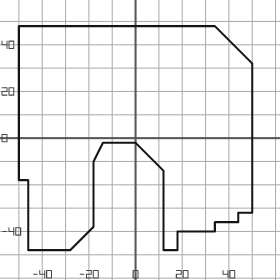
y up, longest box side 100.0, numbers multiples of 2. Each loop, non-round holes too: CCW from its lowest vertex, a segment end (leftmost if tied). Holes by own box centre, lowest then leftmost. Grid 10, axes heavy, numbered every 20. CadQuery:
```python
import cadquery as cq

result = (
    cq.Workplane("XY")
    .moveTo(-46.0, -48.0)
    .lineTo(-28.0, -48.0)
    .lineTo(-18.0, -38.0)
    .lineTo(-18.0, -10.0)
    .lineTo(-14.0, -2.0)
    .lineTo(0.0, -2.0)
    .lineTo(12.0, -14.0)
    .lineTo(12.0, -48.0)
    .lineTo(18.0, -48.0)
    .lineTo(18.0, -40.0)
    .lineTo(34.0, -40.0)
    .lineTo(34.0, -36.0)
    .lineTo(44.0, -36.0)
    .lineTo(44.0, -32.0)
    .lineTo(50.0, -32.0)
    .lineTo(50.0, 32.0)
    .lineTo(34.0, 48.0)
    .lineTo(-50.0, 48.0)
    .lineTo(-50.0, -18.0)
    .lineTo(-46.0, -18.0)
    .close()
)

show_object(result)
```